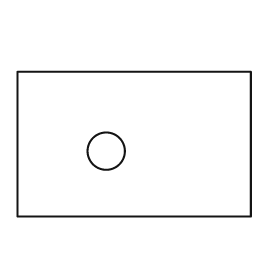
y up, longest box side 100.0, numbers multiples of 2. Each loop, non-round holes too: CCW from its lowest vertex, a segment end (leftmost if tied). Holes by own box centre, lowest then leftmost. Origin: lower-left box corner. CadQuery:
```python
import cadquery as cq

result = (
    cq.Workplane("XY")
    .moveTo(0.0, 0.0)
    .lineTo(100.0, 0.0)
    .lineTo(100.0, 62.0)
    .lineTo(0.0, 62.0)
    .close()
    .moveTo(38.0, 28.0)
    .circle(8.0)
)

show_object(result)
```